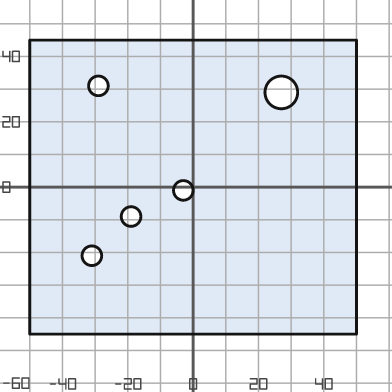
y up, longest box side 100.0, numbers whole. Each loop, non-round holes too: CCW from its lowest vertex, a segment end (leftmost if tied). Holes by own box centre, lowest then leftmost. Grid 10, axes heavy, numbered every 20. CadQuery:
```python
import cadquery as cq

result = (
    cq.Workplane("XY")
    .moveTo(-50.0, -45.0)
    .lineTo(50.0, -45.0)
    .lineTo(50.0, 45.0)
    .lineTo(-50.0, 45.0)
    .close()
    .moveTo(-31.0, -21.0)
    .circle(3.0)
    .moveTo(-19.0, -9.0)
    .circle(3.0)
    .moveTo(-3.0, -1.0)
    .circle(3.0)
    .moveTo(27.0, 29.0)
    .circle(5.0)
    .moveTo(-29.0, 31.0)
    .circle(3.0)
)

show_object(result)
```